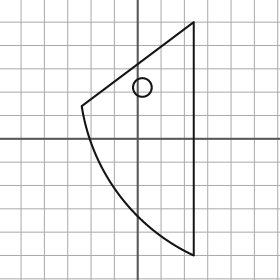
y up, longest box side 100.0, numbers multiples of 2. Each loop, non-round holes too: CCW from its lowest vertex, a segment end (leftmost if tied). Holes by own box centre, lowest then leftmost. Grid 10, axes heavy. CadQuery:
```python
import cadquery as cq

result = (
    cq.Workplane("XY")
    .moveTo(24.0, -50.0)
    .lineTo(24.0, 50.0)
    .lineTo(-24.0, 14.0)
    .threePointArc((-8.0, -24.0), (24.0, -50.0))
    .close()
    .moveTo(2.0, 22.0)
    .circle(4.0)
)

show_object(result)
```